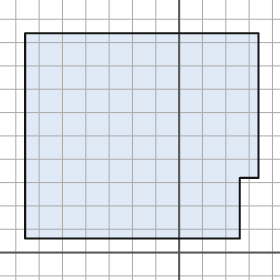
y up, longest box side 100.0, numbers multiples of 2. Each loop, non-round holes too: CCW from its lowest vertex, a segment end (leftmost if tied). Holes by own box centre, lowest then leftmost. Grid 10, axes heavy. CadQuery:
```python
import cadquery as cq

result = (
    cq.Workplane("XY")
    .moveTo(-66.0, 6.0)
    .lineTo(26.0, 6.0)
    .lineTo(26.0, 32.0)
    .lineTo(34.0, 32.0)
    .lineTo(34.0, 94.0)
    .lineTo(-66.0, 94.0)
    .close()
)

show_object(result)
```